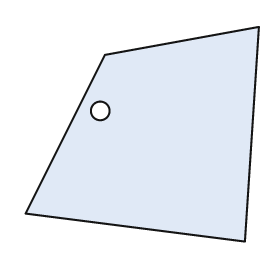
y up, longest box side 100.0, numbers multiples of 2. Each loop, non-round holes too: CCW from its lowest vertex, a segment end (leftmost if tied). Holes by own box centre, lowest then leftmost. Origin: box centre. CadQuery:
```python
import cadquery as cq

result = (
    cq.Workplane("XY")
    .moveTo(44.0, -46.0)
    .lineTo(50.0, 46.0)
    .lineTo(-16.0, 34.0)
    .lineTo(-50.0, -34.0)
    .close()
    .moveTo(-18.0, 10.0)
    .circle(4.0)
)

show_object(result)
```